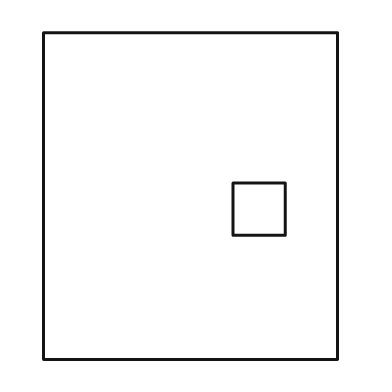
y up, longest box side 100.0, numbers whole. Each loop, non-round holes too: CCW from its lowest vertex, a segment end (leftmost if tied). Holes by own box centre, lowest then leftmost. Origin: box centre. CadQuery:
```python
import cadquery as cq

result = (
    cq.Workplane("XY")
    .moveTo(-45.0, -50.0)
    .lineTo(45.0, -50.0)
    .lineTo(45.0, 50.0)
    .lineTo(-45.0, 50.0)
    .close()
    .moveTo(13.0, -12.0)
    .lineTo(29.0, -12.0)
    .lineTo(29.0, 4.0)
    .lineTo(13.0, 4.0)
    .close()
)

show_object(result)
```